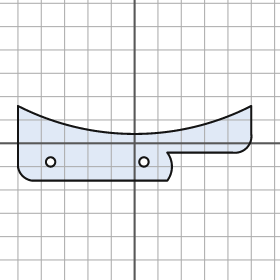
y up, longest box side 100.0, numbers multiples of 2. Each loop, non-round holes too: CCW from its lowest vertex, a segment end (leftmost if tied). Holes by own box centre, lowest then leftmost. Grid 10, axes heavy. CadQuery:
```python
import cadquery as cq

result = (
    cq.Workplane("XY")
    .moveTo(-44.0, -16.0)
    .lineTo(14.0, -16.0)
    .threePointArc((16.0, -10.0), (14.0, -4.0))
    .lineTo(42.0, -4.0)
    .threePointArc((48.0, -2.0), (50.0, 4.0))
    .lineTo(50.0, 16.0)
    .threePointArc((0.0, 4.0), (-50.0, 16.0))
    .lineTo(-50.0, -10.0)
    .threePointArc((-48.0, -14.0), (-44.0, -16.0))
    .close()
    .moveTo(-36.0, -8.0)
    .circle(2.0)
    .moveTo(4.0, -8.0)
    .circle(2.0)
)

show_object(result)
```